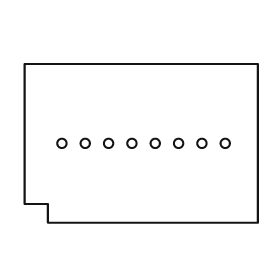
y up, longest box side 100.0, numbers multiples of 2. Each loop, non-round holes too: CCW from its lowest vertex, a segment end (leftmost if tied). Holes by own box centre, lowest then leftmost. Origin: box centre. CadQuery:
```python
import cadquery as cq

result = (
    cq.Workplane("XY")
    .moveTo(-40.0, -34.0)
    .lineTo(50.0, -34.0)
    .lineTo(50.0, 34.0)
    .lineTo(-50.0, 34.0)
    .lineTo(-50.0, -26.0)
    .lineTo(-40.0, -26.0)
    .close()
    .moveTo(-34.0, 0.0)
    .circle(2.0)
    .moveTo(-24.0, 0.0)
    .circle(2.0)
    .moveTo(-14.0, 0.0)
    .circle(2.0)
    .moveTo(-4.0, 0.0)
    .circle(2.0)
    .moveTo(6.0, 0.0)
    .circle(2.0)
    .moveTo(16.0, 0.0)
    .circle(2.0)
    .moveTo(26.0, 0.0)
    .circle(2.0)
    .moveTo(36.0, 0.0)
    .circle(2.0)
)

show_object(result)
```